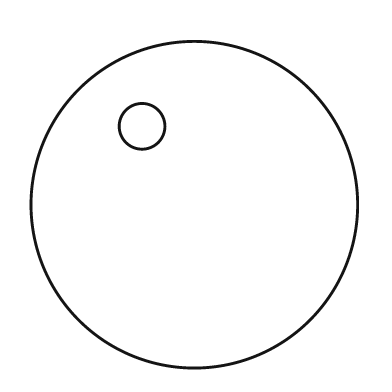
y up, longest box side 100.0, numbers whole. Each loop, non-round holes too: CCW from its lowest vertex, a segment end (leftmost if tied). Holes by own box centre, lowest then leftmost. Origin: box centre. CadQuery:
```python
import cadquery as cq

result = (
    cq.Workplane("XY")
    .moveTo(0.0, 0.0)
    .circle(50.0)
    .moveTo(-16.0, 24.0)
    .circle(7.0)
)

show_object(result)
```